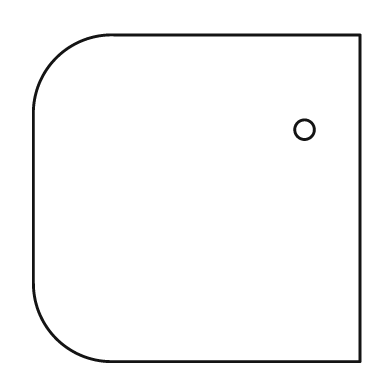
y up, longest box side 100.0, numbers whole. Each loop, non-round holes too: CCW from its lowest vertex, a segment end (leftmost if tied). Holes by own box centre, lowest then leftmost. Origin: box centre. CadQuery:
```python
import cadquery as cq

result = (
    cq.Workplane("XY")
    .moveTo(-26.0, -50.0)
    .lineTo(50.0, -50.0)
    .lineTo(50.0, 50.0)
    .lineTo(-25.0, 50.0)
    .threePointArc((-43.0, 43.0), (-50.0, 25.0))
    .lineTo(-50.0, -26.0)
    .threePointArc((-43.0, -43.0), (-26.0, -50.0))
    .close()
    .moveTo(33.0, 21.0)
    .circle(3.0)
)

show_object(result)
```